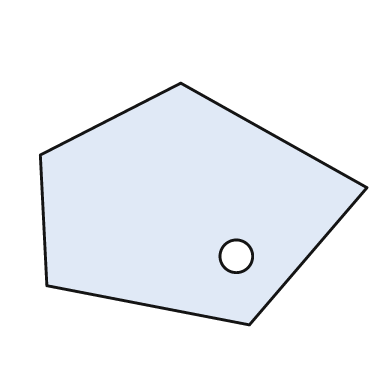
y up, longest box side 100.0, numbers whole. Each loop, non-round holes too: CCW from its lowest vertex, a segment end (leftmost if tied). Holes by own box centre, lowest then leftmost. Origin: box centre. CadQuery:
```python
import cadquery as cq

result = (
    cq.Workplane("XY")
    .moveTo(14.0, -37.0)
    .lineTo(50.0, 5.0)
    .lineTo(-7.0, 37.0)
    .lineTo(-50.0, 15.0)
    .lineTo(-48.0, -25.0)
    .close()
    .moveTo(10.0, -16.0)
    .circle(5.0)
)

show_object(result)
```